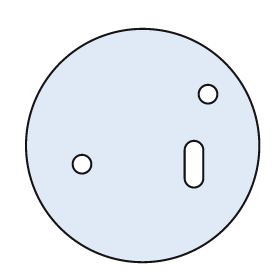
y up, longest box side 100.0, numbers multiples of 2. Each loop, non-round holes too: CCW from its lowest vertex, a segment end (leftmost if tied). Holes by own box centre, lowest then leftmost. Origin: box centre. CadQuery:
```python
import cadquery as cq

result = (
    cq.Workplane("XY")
    .moveTo(0.0, 0.0)
    .circle(50.0)
    .moveTo(-26.0, -8.0)
    .circle(4.0)
    .moveTo(18.0, -14.0)
    .threePointArc((22.0, -18.0), (26.0, -14.0))
    .lineTo(26.0, -2.0)
    .threePointArc((22.0, 2.0), (18.0, -2.0))
    .close()
    .moveTo(28.0, 22.0)
    .circle(4.0)
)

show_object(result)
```